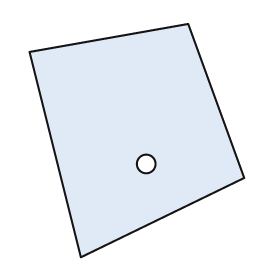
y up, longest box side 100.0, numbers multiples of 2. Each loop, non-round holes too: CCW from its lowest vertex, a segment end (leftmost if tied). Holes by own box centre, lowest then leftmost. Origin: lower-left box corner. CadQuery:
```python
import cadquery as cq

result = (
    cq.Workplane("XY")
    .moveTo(22.0, 0.0)
    .lineTo(92.0, 34.0)
    .lineTo(68.0, 100.0)
    .lineTo(0.0, 88.0)
    .close()
    .moveTo(50.0, 40.0)
    .circle(4.0)
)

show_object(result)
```